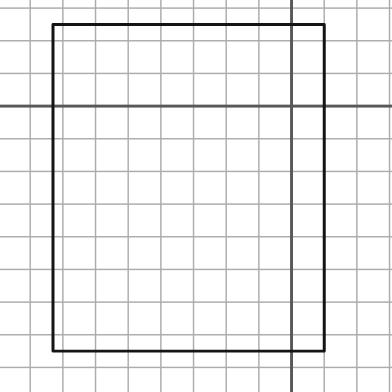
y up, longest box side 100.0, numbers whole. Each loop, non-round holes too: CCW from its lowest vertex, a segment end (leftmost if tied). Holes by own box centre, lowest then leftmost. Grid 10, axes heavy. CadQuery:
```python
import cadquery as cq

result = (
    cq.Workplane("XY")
    .moveTo(-73.0, -75.0)
    .lineTo(10.0, -75.0)
    .lineTo(10.0, 25.0)
    .lineTo(-73.0, 25.0)
    .close()
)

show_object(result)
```